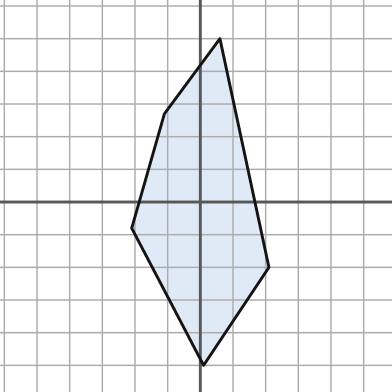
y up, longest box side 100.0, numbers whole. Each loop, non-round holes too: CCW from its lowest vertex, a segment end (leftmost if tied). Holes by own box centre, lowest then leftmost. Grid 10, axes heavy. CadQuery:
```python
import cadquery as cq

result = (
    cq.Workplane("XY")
    .moveTo(1.0, -50.0)
    .lineTo(21.0, -20.0)
    .lineTo(6.0, 50.0)
    .lineTo(-11.0, 27.0)
    .lineTo(-21.0, -8.0)
    .close()
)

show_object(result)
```